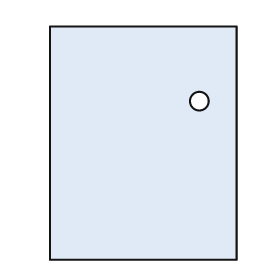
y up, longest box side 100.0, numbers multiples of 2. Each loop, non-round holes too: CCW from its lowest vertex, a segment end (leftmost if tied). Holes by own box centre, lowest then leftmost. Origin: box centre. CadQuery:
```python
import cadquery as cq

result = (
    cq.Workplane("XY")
    .moveTo(-40.0, -50.0)
    .lineTo(40.0, -50.0)
    .lineTo(40.0, 50.0)
    .lineTo(-40.0, 50.0)
    .close()
    .moveTo(24.0, 18.0)
    .circle(4.0)
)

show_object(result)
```